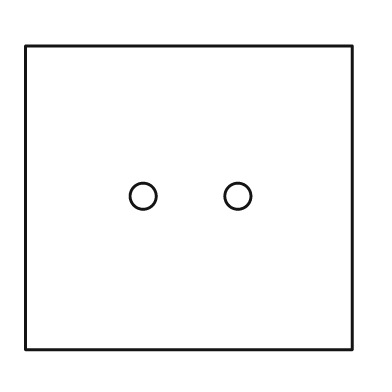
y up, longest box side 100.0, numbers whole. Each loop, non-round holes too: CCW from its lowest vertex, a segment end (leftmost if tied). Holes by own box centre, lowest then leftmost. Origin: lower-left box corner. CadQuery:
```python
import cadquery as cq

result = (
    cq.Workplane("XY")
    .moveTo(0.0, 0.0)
    .lineTo(100.0, 0.0)
    .lineTo(100.0, 93.0)
    .lineTo(0.0, 93.0)
    .close()
    .moveTo(36.0, 47.0)
    .circle(4.0)
    .moveTo(65.0, 47.0)
    .circle(4.0)
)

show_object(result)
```